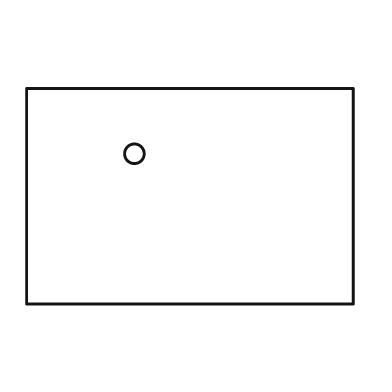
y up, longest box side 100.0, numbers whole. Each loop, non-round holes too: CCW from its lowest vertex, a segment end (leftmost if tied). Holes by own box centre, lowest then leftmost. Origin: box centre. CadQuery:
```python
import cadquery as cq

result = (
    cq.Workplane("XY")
    .moveTo(-50.0, -33.0)
    .lineTo(50.0, -33.0)
    .lineTo(50.0, 33.0)
    .lineTo(-50.0, 33.0)
    .close()
    .moveTo(-17.0, 13.0)
    .circle(3.0)
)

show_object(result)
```